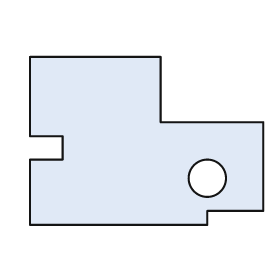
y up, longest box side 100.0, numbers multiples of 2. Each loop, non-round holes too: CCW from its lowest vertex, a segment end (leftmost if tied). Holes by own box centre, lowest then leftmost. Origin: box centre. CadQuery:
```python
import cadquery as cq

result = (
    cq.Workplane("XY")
    .moveTo(-50.0, -36.0)
    .lineTo(26.0, -36.0)
    .lineTo(26.0, -30.0)
    .lineTo(50.0, -30.0)
    .lineTo(50.0, 8.0)
    .lineTo(6.0, 8.0)
    .lineTo(6.0, 36.0)
    .lineTo(-50.0, 36.0)
    .lineTo(-50.0, 2.0)
    .lineTo(-36.0, 2.0)
    .lineTo(-36.0, -8.0)
    .lineTo(-50.0, -8.0)
    .close()
    .moveTo(26.0, -16.0)
    .circle(8.0)
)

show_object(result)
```